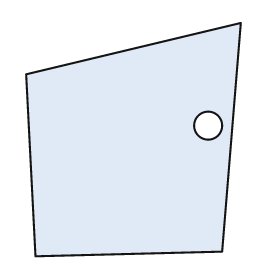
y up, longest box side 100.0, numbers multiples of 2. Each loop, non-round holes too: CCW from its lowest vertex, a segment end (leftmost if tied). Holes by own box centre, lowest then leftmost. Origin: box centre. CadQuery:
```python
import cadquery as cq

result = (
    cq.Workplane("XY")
    .moveTo(-42.0, -50.0)
    .lineTo(38.0, -48.0)
    .lineTo(46.0, 50.0)
    .lineTo(-46.0, 28.0)
    .close()
    .moveTo(32.0, 6.0)
    .circle(6.0)
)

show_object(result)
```